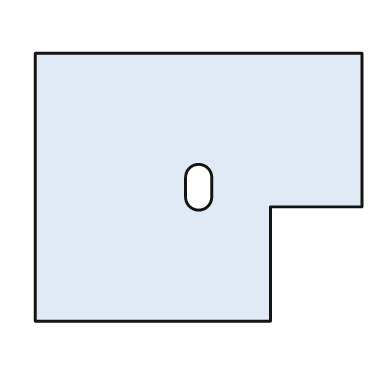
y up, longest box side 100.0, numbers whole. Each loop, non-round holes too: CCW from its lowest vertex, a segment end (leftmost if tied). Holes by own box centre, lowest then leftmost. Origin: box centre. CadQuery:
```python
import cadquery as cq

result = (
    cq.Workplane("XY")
    .moveTo(-50.0, -41.0)
    .lineTo(22.0, -41.0)
    .lineTo(22.0, -6.0)
    .lineTo(50.0, -6.0)
    .lineTo(50.0, 41.0)
    .lineTo(-50.0, 41.0)
    .close()
    .moveTo(-4.0, -3.0)
    .threePointArc((0.0, -7.0), (4.0, -3.0))
    .lineTo(4.0, 3.0)
    .threePointArc((0.0, 7.0), (-4.0, 3.0))
    .close()
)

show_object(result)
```